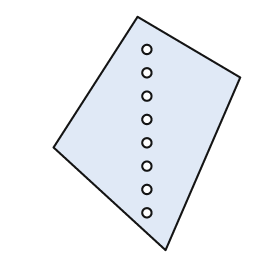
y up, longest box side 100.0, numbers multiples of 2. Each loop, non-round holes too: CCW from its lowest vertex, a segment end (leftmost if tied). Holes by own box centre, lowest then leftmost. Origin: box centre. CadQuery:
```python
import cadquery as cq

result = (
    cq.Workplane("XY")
    .moveTo(8.0, -50.0)
    .lineTo(40.0, 24.0)
    .lineTo(-4.0, 50.0)
    .lineTo(-40.0, -6.0)
    .close()
    .moveTo(0.0, -34.0)
    .circle(2.0)
    .moveTo(0.0, -24.0)
    .circle(2.0)
    .moveTo(0.0, -14.0)
    .circle(2.0)
    .moveTo(0.0, -4.0)
    .circle(2.0)
    .moveTo(0.0, 6.0)
    .circle(2.0)
    .moveTo(0.0, 16.0)
    .circle(2.0)
    .moveTo(0.0, 26.0)
    .circle(2.0)
    .moveTo(0.0, 36.0)
    .circle(2.0)
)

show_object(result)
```